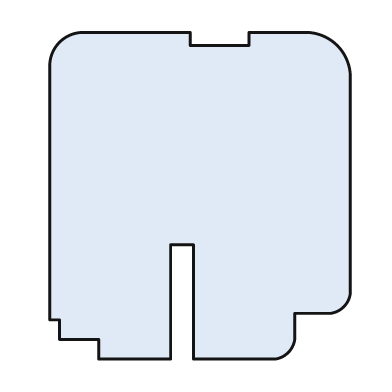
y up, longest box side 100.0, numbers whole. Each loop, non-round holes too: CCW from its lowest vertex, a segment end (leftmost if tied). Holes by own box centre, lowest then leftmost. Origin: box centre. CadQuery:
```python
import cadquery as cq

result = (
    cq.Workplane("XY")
    .moveTo(-31.0, -50.0)
    .lineTo(-9.0, -50.0)
    .lineTo(-9.0, -15.0)
    .lineTo(-2.0, -15.0)
    .lineTo(-2.0, -50.0)
    .lineTo(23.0, -50.0)
    .threePointArc((27.0, -48.0), (29.0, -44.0))
    .lineTo(29.0, -36.0)
    .lineTo(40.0, -36.0)
    .threePointArc((44.0, -34.0), (46.0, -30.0))
    .lineTo(46.0, 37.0)
    .threePointArc((42.0, 46.0), (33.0, 50.0))
    .lineTo(15.0, 50.0)
    .lineTo(15.0, 46.0)
    .lineTo(-3.0, 46.0)
    .lineTo(-3.0, 50.0)
    .lineTo(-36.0, 50.0)
    .threePointArc((-43.0, 47.0), (-46.0, 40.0))
    .lineTo(-46.0, -38.0)
    .lineTo(-43.0, -38.0)
    .lineTo(-43.0, -44.0)
    .lineTo(-31.0, -44.0)
    .close()
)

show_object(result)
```